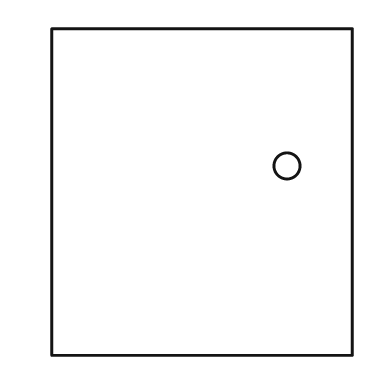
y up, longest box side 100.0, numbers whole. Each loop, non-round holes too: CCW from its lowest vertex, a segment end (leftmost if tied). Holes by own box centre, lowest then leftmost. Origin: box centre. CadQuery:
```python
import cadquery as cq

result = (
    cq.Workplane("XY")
    .moveTo(-46.0, -50.0)
    .lineTo(46.0, -50.0)
    .lineTo(46.0, 50.0)
    .lineTo(-46.0, 50.0)
    .close()
    .moveTo(26.0, 8.0)
    .circle(4.0)
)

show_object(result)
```